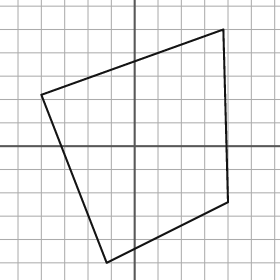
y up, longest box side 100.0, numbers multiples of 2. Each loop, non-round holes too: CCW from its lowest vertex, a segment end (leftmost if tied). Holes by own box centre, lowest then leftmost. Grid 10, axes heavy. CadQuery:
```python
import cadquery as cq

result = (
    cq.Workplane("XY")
    .moveTo(-12.0, -50.0)
    .lineTo(40.0, -24.0)
    .lineTo(38.0, 50.0)
    .lineTo(-40.0, 22.0)
    .close()
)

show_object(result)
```